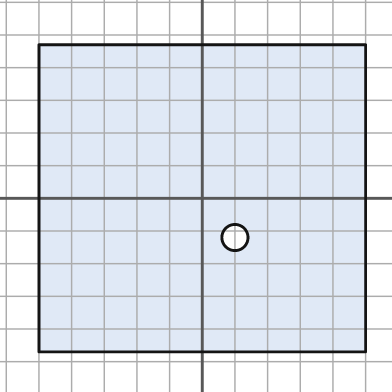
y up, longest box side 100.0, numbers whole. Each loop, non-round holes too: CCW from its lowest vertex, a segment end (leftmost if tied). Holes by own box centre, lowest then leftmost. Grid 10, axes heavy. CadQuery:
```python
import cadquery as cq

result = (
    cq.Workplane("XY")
    .moveTo(-50.0, -47.0)
    .lineTo(50.0, -47.0)
    .lineTo(50.0, 47.0)
    .lineTo(-50.0, 47.0)
    .close()
    .moveTo(10.0, -12.0)
    .circle(4.0)
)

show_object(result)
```